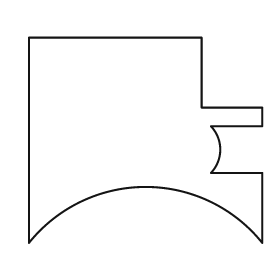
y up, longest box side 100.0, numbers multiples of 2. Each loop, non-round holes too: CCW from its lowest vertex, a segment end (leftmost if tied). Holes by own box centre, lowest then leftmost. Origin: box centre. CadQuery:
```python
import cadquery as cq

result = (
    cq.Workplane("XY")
    .moveTo(-50.0, -44.0)
    .threePointArc((0.0, -20.0), (50.0, -44.0))
    .lineTo(50.0, -14.0)
    .lineTo(28.0, -14.0)
    .threePointArc((32.0, -4.0), (28.0, 6.0))
    .lineTo(50.0, 6.0)
    .lineTo(50.0, 14.0)
    .lineTo(24.0, 14.0)
    .lineTo(24.0, 44.0)
    .lineTo(-50.0, 44.0)
    .close()
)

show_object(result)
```